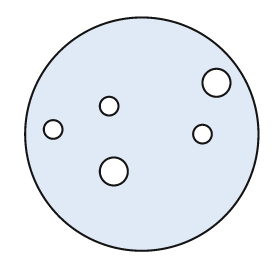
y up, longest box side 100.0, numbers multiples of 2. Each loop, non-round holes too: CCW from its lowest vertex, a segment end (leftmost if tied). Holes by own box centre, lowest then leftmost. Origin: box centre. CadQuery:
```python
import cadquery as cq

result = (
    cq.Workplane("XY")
    .moveTo(0.0, 0.0)
    .circle(50.0)
    .moveTo(-12.0, -16.0)
    .circle(6.0)
    .moveTo(26.0, 0.0)
    .circle(4.0)
    .moveTo(-38.0, 2.0)
    .circle(4.0)
    .moveTo(-14.0, 12.0)
    .circle(4.0)
    .moveTo(32.0, 22.0)
    .circle(6.0)
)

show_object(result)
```